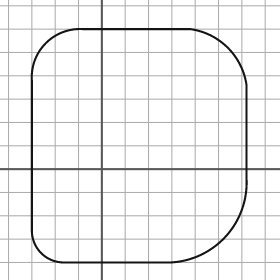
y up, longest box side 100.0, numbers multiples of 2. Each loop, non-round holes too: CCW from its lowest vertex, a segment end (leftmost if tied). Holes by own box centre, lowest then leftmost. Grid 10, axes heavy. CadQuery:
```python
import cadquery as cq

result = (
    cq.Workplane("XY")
    .moveTo(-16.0, -40.0)
    .lineTo(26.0, -40.0)
    .threePointArc((52.0, -30.0), (62.0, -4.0))
    .lineTo(62.0, 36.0)
    .threePointArc((54.0, 52.0), (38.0, 60.0))
    .lineTo(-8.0, 60.0)
    .threePointArc((-24.0, 54.0), (-30.0, 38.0))
    .lineTo(-30.0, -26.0)
    .threePointArc((-26.0, -36.0), (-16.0, -40.0))
    .close()
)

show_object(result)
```